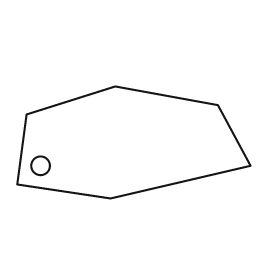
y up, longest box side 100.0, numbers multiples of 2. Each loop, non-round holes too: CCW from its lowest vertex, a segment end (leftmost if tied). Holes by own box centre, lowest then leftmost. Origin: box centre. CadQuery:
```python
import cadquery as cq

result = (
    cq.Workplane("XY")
    .moveTo(-10.0, -24.0)
    .lineTo(50.0, -10.0)
    .lineTo(36.0, 16.0)
    .lineTo(-8.0, 24.0)
    .lineTo(-46.0, 12.0)
    .lineTo(-50.0, -18.0)
    .close()
    .moveTo(-40.0, -10.0)
    .circle(4.0)
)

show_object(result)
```